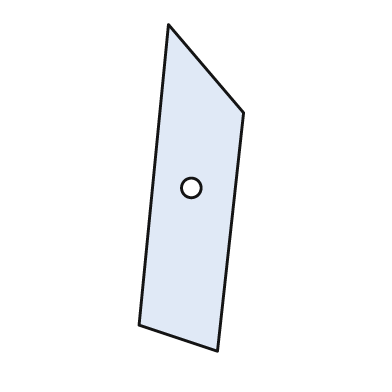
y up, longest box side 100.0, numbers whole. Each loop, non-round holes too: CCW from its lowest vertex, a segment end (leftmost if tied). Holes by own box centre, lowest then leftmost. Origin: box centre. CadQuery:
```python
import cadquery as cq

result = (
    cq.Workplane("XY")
    .moveTo(8.0, -50.0)
    .lineTo(16.0, 23.0)
    .lineTo(-7.0, 50.0)
    .lineTo(-16.0, -42.0)
    .close()
    .moveTo(0.0, 0.0)
    .circle(3.0)
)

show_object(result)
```